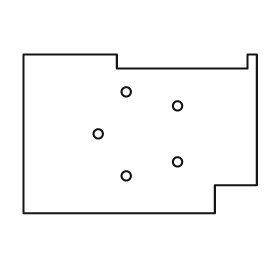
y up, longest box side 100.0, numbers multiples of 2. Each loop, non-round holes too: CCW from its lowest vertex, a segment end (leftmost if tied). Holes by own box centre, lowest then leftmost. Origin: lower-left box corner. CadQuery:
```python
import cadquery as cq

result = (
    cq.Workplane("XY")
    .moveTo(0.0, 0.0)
    .lineTo(82.0, 0.0)
    .lineTo(82.0, 12.0)
    .lineTo(100.0, 12.0)
    .lineTo(100.0, 68.0)
    .lineTo(96.0, 68.0)
    .lineTo(96.0, 62.0)
    .lineTo(40.0, 62.0)
    .lineTo(40.0, 68.0)
    .lineTo(0.0, 68.0)
    .close()
    .moveTo(44.0, 16.0)
    .circle(2.0)
    .moveTo(66.0, 22.0)
    .circle(2.0)
    .moveTo(32.0, 34.0)
    .circle(2.0)
    .moveTo(66.0, 46.0)
    .circle(2.0)
    .moveTo(44.0, 52.0)
    .circle(2.0)
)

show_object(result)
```